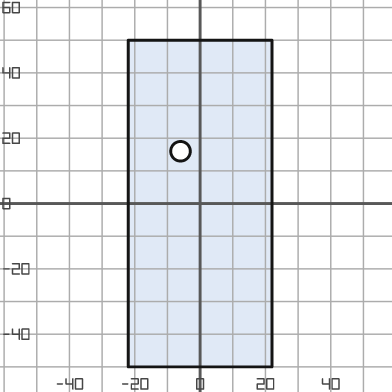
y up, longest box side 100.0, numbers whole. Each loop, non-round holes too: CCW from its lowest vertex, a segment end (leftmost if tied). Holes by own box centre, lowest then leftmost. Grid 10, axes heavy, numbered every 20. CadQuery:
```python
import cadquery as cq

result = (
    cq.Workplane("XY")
    .moveTo(-22.0, -50.0)
    .lineTo(22.0, -50.0)
    .lineTo(22.0, 50.0)
    .lineTo(-22.0, 50.0)
    .close()
    .moveTo(-6.0, 16.0)
    .circle(3.0)
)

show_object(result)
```